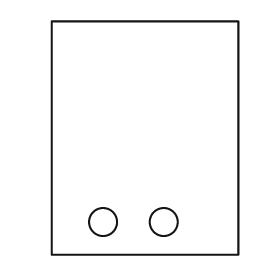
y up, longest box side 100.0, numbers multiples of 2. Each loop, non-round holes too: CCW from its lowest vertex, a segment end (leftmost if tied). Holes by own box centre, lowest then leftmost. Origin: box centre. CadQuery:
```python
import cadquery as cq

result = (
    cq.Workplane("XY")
    .moveTo(-40.0, -50.0)
    .lineTo(40.0, -50.0)
    .lineTo(40.0, 50.0)
    .lineTo(-40.0, 50.0)
    .close()
    .moveTo(-18.0, -36.0)
    .circle(6.0)
    .moveTo(8.0, -36.0)
    .circle(6.0)
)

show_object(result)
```